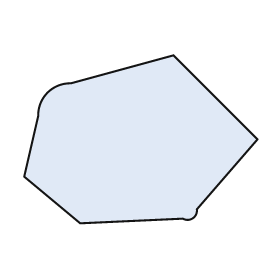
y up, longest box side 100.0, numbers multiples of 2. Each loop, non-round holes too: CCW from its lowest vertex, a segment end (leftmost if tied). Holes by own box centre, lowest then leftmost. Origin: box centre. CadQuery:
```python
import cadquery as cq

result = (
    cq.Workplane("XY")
    .moveTo(-26.0, -36.0)
    .lineTo(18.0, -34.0)
    .threePointArc((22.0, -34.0), (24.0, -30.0))
    .lineTo(50.0, 0.0)
    .lineTo(14.0, 36.0)
    .lineTo(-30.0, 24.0)
    .threePointArc((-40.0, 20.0), (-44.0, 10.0))
    .lineTo(-50.0, -16.0)
    .close()
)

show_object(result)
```